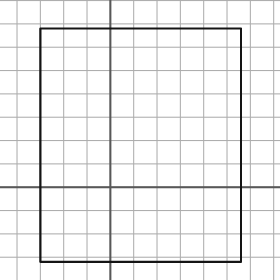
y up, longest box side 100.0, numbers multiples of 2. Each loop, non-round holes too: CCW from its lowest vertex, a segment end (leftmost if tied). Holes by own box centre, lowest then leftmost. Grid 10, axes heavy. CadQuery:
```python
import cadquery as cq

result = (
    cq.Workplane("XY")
    .moveTo(-30.0, -32.0)
    .lineTo(56.0, -32.0)
    .lineTo(56.0, 68.0)
    .lineTo(-30.0, 68.0)
    .close()
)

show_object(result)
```